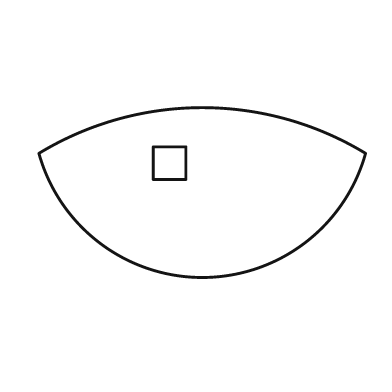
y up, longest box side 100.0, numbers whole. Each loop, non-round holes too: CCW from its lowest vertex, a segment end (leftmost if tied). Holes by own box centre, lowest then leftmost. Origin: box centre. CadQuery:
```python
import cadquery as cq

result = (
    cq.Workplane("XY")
    .moveTo(-50.0, 12.0)
    .threePointArc((0.0, -26.0), (50.0, 12.0))
    .threePointArc((0.0, 26.0), (-50.0, 12.0))
    .close()
    .moveTo(-15.0, 4.0)
    .lineTo(-5.0, 4.0)
    .lineTo(-5.0, 14.0)
    .lineTo(-15.0, 14.0)
    .close()
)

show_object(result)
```